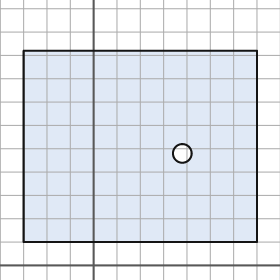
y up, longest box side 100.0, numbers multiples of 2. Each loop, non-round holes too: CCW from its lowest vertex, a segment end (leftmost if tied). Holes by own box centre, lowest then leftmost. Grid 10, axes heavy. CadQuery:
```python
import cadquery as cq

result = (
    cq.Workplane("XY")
    .moveTo(-30.0, 10.0)
    .lineTo(70.0, 10.0)
    .lineTo(70.0, 92.0)
    .lineTo(-30.0, 92.0)
    .close()
    .moveTo(38.0, 48.0)
    .circle(4.0)
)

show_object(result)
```